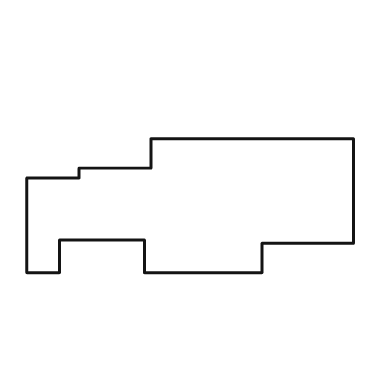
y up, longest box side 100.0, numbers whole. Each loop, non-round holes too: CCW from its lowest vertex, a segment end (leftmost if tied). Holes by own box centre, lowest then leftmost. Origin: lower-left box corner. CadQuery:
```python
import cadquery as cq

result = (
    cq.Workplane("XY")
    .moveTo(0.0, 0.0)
    .lineTo(10.0, 0.0)
    .lineTo(10.0, 10.0)
    .lineTo(36.0, 10.0)
    .lineTo(36.0, 0.0)
    .lineTo(72.0, 0.0)
    .lineTo(72.0, 9.0)
    .lineTo(100.0, 9.0)
    .lineTo(100.0, 41.0)
    .lineTo(38.0, 41.0)
    .lineTo(38.0, 32.0)
    .lineTo(16.0, 32.0)
    .lineTo(16.0, 29.0)
    .lineTo(0.0, 29.0)
    .close()
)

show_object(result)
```